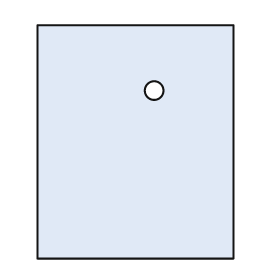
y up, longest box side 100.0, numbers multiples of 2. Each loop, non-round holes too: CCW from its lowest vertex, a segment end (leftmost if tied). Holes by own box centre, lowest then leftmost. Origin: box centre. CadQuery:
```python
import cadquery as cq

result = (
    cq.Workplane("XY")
    .moveTo(-42.0, -50.0)
    .lineTo(42.0, -50.0)
    .lineTo(42.0, 50.0)
    .lineTo(-42.0, 50.0)
    .close()
    .moveTo(8.0, 22.0)
    .circle(4.0)
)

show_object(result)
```